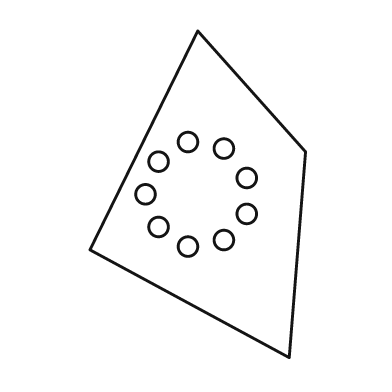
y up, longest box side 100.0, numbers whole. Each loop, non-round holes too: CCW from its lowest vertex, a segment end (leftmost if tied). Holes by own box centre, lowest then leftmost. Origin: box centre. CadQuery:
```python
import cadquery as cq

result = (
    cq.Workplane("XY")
    .moveTo(28.0, -50.0)
    .lineTo(33.0, 13.0)
    .lineTo(0.0, 50.0)
    .lineTo(-33.0, -17.0)
    .close()
    .moveTo(-3.0, -16.0)
    .circle(3.0)
    .moveTo(8.0, -14.0)
    .circle(3.0)
    .moveTo(-12.0, -10.0)
    .circle(3.0)
    .moveTo(15.0, -6.0)
    .circle(3.0)
    .moveTo(-16.0, 0.0)
    .circle(3.0)
    .moveTo(15.0, 5.0)
    .circle(3.0)
    .moveTo(-12.0, 10.0)
    .circle(3.0)
    .moveTo(8.0, 14.0)
    .circle(3.0)
    .moveTo(-3.0, 16.0)
    .circle(3.0)
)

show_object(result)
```